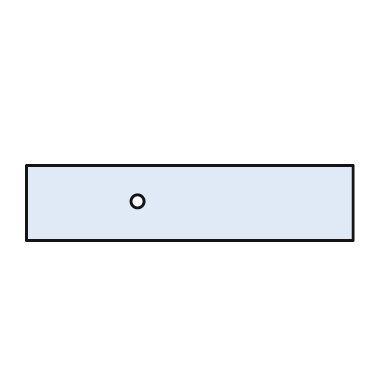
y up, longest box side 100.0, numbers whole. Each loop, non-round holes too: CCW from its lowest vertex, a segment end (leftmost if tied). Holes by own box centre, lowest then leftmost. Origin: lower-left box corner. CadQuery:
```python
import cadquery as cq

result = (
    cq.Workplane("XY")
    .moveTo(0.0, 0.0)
    .lineTo(100.0, 0.0)
    .lineTo(100.0, 23.0)
    .lineTo(0.0, 23.0)
    .close()
    .moveTo(34.0, 12.0)
    .circle(2.0)
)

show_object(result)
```